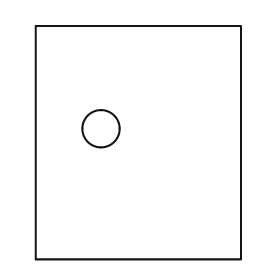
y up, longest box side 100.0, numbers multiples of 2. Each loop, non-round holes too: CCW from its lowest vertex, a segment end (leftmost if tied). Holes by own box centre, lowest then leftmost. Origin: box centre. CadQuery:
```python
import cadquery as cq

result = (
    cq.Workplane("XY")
    .moveTo(-44.0, -50.0)
    .lineTo(44.0, -50.0)
    .lineTo(44.0, 50.0)
    .lineTo(-44.0, 50.0)
    .close()
    .moveTo(-16.0, 6.0)
    .circle(8.0)
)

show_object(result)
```